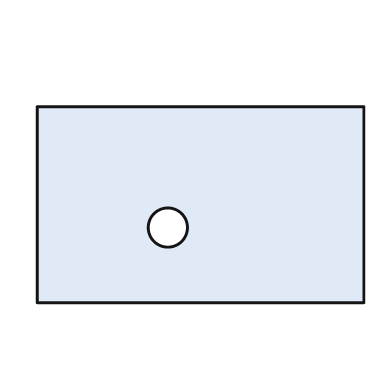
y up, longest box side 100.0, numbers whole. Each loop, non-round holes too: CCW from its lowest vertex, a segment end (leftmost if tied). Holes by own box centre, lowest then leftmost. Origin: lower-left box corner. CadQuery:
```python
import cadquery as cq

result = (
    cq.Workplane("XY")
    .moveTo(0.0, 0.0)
    .lineTo(100.0, 0.0)
    .lineTo(100.0, 60.0)
    .lineTo(0.0, 60.0)
    .close()
    .moveTo(40.0, 23.0)
    .circle(6.0)
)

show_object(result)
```